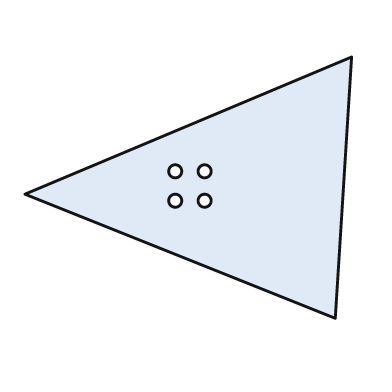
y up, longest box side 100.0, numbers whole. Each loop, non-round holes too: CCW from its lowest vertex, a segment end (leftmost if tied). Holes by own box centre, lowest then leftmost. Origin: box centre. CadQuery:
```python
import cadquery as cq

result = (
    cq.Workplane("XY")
    .moveTo(45.0, -40.0)
    .lineTo(50.0, 40.0)
    .lineTo(-50.0, -2.0)
    .close()
    .moveTo(-4.0, -4.0)
    .circle(2.0)
    .moveTo(5.0, -4.0)
    .circle(2.0)
    .moveTo(-4.0, 5.0)
    .circle(2.0)
    .moveTo(5.0, 5.0)
    .circle(2.0)
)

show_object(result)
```